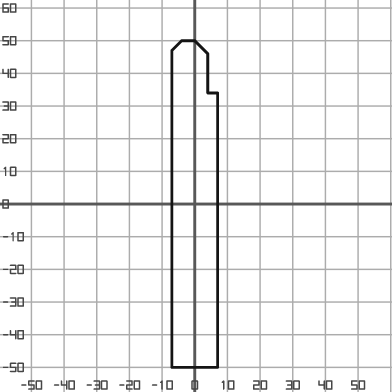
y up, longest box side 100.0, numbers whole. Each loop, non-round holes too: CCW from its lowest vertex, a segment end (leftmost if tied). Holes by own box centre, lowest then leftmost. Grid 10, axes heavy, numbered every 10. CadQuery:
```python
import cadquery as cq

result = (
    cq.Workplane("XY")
    .moveTo(-7.0, -50.0)
    .lineTo(7.0, -50.0)
    .lineTo(7.0, 34.0)
    .lineTo(4.0, 34.0)
    .lineTo(4.0, 46.0)
    .lineTo(0.0, 50.0)
    .lineTo(-4.0, 50.0)
    .lineTo(-7.0, 47.0)
    .close()
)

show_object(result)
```